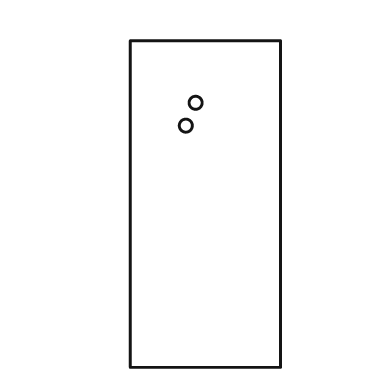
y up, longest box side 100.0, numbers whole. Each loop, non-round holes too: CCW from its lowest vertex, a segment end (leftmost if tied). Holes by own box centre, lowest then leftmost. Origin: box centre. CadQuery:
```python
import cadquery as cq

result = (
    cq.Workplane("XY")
    .moveTo(-23.0, -50.0)
    .lineTo(23.0, -50.0)
    .lineTo(23.0, 50.0)
    .lineTo(-23.0, 50.0)
    .close()
    .moveTo(-6.0, 24.0)
    .circle(2.0)
    .moveTo(-3.0, 31.0)
    .circle(2.0)
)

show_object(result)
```